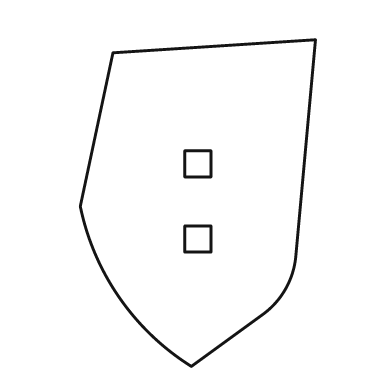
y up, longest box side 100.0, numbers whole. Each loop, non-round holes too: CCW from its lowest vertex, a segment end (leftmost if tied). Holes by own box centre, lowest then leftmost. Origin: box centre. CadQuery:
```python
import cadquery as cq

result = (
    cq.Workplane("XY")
    .moveTo(-2.0, -50.0)
    .lineTo(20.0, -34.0)
    .threePointArc((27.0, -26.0), (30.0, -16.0))
    .lineTo(36.0, 50.0)
    .lineTo(-26.0, 46.0)
    .lineTo(-36.0, -1.0)
    .threePointArc((-24.0, -29.0), (-2.0, -50.0))
    .close()
    .moveTo(-4.0, -15.0)
    .lineTo(4.0, -15.0)
    .lineTo(4.0, -7.0)
    .lineTo(-4.0, -7.0)
    .close()
    .moveTo(-4.0, 8.0)
    .lineTo(4.0, 8.0)
    .lineTo(4.0, 16.0)
    .lineTo(-4.0, 16.0)
    .close()
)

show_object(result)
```